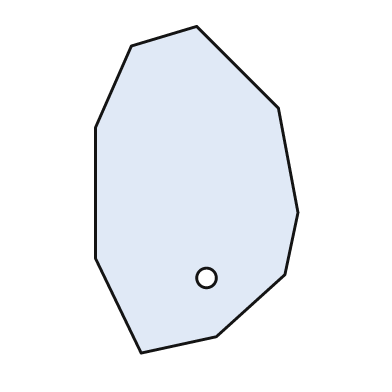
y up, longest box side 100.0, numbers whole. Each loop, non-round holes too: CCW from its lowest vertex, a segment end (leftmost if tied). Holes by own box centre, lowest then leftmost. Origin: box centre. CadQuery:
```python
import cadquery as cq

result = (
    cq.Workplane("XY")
    .moveTo(-17.0, -50.0)
    .lineTo(6.0, -45.0)
    .lineTo(27.0, -26.0)
    .lineTo(31.0, -7.0)
    .lineTo(25.0, 25.0)
    .lineTo(0.0, 50.0)
    .lineTo(-20.0, 44.0)
    .lineTo(-31.0, 19.0)
    .lineTo(-31.0, -21.0)
    .close()
    .moveTo(3.0, -27.0)
    .circle(3.0)
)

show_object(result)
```